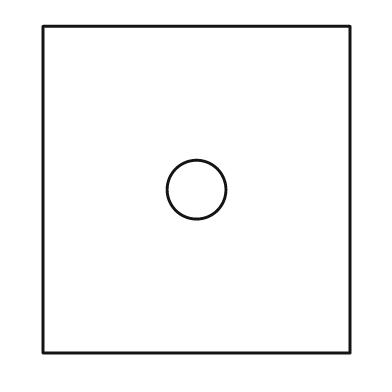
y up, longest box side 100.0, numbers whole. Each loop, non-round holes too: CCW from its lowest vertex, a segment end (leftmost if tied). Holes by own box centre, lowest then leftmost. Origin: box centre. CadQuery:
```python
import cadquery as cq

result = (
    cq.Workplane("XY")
    .moveTo(-47.0, -50.0)
    .lineTo(47.0, -50.0)
    .lineTo(47.0, 50.0)
    .lineTo(-47.0, 50.0)
    .close()
    .moveTo(0.0, 0.0)
    .circle(9.0)
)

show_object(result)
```